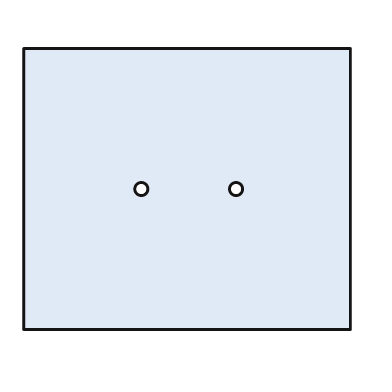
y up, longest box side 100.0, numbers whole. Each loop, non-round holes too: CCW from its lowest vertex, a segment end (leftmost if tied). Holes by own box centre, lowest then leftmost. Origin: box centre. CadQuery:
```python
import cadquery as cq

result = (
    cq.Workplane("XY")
    .moveTo(-50.0, -43.0)
    .lineTo(50.0, -43.0)
    .lineTo(50.0, 43.0)
    .lineTo(-50.0, 43.0)
    .close()
    .moveTo(-14.0, 0.0)
    .circle(2.0)
    .moveTo(15.0, 0.0)
    .circle(2.0)
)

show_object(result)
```